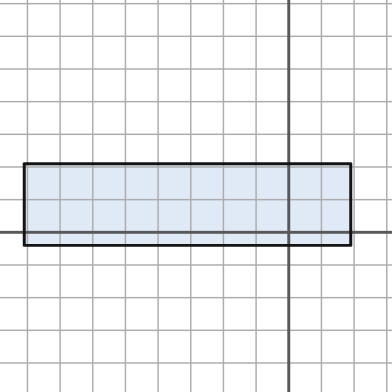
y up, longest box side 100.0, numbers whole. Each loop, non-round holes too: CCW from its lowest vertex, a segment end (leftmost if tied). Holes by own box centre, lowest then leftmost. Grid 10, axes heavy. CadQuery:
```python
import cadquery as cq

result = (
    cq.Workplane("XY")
    .moveTo(-81.0, -4.0)
    .lineTo(19.0, -4.0)
    .lineTo(19.0, 21.0)
    .lineTo(-81.0, 21.0)
    .close()
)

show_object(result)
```